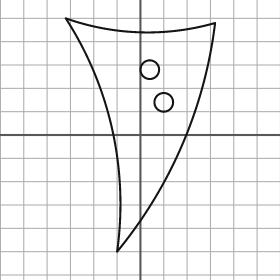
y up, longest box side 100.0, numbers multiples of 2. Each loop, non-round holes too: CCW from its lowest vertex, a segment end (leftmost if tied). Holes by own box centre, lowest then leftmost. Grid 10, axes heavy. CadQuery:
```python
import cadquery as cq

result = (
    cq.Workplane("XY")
    .moveTo(-10.0, -50.0)
    .threePointArc((18.0, -4.0), (32.0, 48.0))
    .threePointArc((0.0, 44.0), (-32.0, 50.0))
    .threePointArc((-12.0, 2.0), (-10.0, -50.0))
    .close()
    .moveTo(10.0, 14.0)
    .circle(4.0)
    .moveTo(4.0, 28.0)
    .circle(4.0)
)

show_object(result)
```